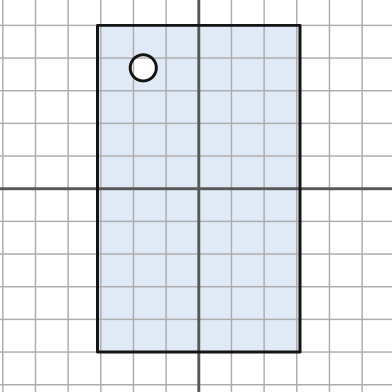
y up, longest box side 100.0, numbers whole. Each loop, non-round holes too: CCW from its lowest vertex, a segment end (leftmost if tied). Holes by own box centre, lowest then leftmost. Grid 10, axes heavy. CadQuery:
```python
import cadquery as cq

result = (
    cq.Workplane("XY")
    .moveTo(-31.0, -50.0)
    .lineTo(31.0, -50.0)
    .lineTo(31.0, 50.0)
    .lineTo(-31.0, 50.0)
    .close()
    .moveTo(-17.0, 37.0)
    .circle(4.0)
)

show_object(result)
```